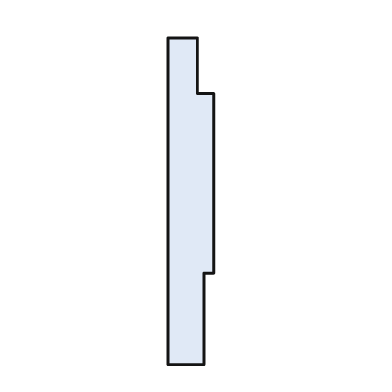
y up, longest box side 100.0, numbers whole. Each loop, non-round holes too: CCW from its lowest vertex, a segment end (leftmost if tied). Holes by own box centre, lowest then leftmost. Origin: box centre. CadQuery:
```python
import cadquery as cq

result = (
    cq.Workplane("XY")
    .moveTo(-7.0, -50.0)
    .lineTo(4.0, -50.0)
    .lineTo(4.0, -22.0)
    .lineTo(7.0, -22.0)
    .lineTo(7.0, 33.0)
    .lineTo(2.0, 33.0)
    .lineTo(2.0, 50.0)
    .lineTo(-7.0, 50.0)
    .close()
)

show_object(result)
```